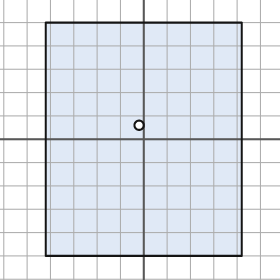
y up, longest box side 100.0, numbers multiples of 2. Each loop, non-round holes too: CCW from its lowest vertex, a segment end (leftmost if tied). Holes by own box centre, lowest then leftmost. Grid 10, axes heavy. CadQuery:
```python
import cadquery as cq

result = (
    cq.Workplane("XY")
    .moveTo(-42.0, -50.0)
    .lineTo(42.0, -50.0)
    .lineTo(42.0, 50.0)
    .lineTo(-42.0, 50.0)
    .close()
    .moveTo(-2.0, 6.0)
    .circle(2.0)
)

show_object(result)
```